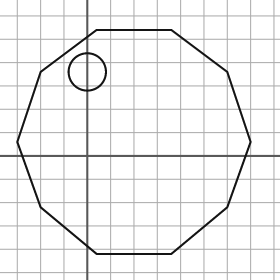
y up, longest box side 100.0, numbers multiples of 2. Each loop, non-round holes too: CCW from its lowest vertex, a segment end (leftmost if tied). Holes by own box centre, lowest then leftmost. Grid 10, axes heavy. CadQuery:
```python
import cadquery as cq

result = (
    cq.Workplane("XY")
    .moveTo(4.0, -42.0)
    .lineTo(36.0, -42.0)
    .lineTo(60.0, -22.0)
    .lineTo(70.0, 6.0)
    .lineTo(60.0, 36.0)
    .lineTo(36.0, 54.0)
    .lineTo(4.0, 54.0)
    .lineTo(-20.0, 36.0)
    .lineTo(-30.0, 6.0)
    .lineTo(-20.0, -22.0)
    .close()
    .moveTo(0.0, 36.0)
    .circle(8.0)
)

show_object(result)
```